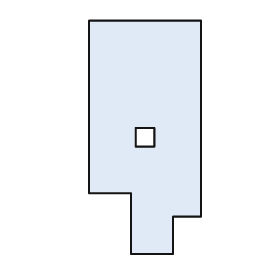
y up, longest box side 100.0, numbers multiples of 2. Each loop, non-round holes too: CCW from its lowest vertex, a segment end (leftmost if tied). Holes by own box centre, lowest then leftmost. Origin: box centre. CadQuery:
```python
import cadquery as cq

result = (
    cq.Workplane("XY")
    .moveTo(-6.0, -50.0)
    .lineTo(12.0, -50.0)
    .lineTo(12.0, -34.0)
    .lineTo(24.0, -34.0)
    .lineTo(24.0, 50.0)
    .lineTo(-24.0, 50.0)
    .lineTo(-24.0, -24.0)
    .lineTo(-6.0, -24.0)
    .close()
    .moveTo(-4.0, -4.0)
    .lineTo(4.0, -4.0)
    .lineTo(4.0, 4.0)
    .lineTo(-4.0, 4.0)
    .close()
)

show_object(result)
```